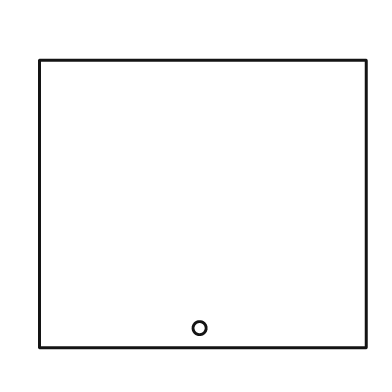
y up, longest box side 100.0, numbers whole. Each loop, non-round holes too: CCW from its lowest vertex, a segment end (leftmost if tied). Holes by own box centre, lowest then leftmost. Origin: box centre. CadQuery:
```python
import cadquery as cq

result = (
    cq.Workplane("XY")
    .moveTo(-50.0, -44.0)
    .lineTo(50.0, -44.0)
    .lineTo(50.0, 44.0)
    .lineTo(-50.0, 44.0)
    .close()
    .moveTo(-1.0, -38.0)
    .circle(2.0)
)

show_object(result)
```